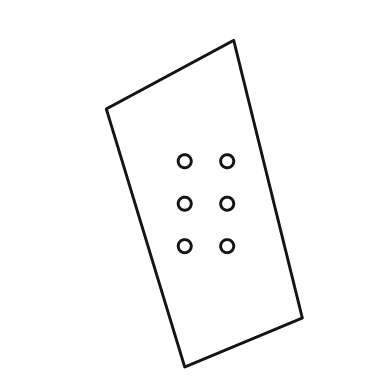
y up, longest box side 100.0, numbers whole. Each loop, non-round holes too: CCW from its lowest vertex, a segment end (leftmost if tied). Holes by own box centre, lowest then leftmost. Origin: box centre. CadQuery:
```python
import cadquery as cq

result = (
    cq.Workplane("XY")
    .moveTo(-6.0, -50.0)
    .lineTo(30.0, -35.0)
    .lineTo(9.0, 50.0)
    .lineTo(-30.0, 29.0)
    .close()
    .moveTo(-6.0, -13.0)
    .circle(2.0)
    .moveTo(7.0, -13.0)
    .circle(2.0)
    .moveTo(-6.0, 0.0)
    .circle(2.0)
    .moveTo(7.0, 0.0)
    .circle(2.0)
    .moveTo(-6.0, 13.0)
    .circle(2.0)
    .moveTo(7.0, 13.0)
    .circle(2.0)
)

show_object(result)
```